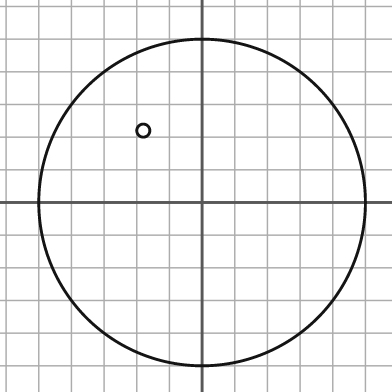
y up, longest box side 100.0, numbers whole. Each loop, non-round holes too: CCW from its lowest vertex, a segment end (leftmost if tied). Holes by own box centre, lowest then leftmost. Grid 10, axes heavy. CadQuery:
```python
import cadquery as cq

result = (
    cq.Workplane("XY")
    .moveTo(0.0, 0.0)
    .circle(50.0)
    .moveTo(-18.0, 22.0)
    .circle(2.0)
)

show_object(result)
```